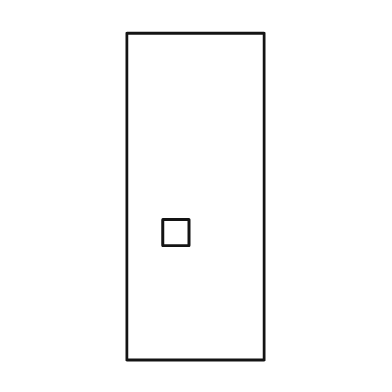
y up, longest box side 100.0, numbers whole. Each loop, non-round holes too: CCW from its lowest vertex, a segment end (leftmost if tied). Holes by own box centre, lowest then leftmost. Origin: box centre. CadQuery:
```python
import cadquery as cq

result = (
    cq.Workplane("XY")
    .moveTo(-21.0, -50.0)
    .lineTo(21.0, -50.0)
    .lineTo(21.0, 50.0)
    .lineTo(-21.0, 50.0)
    .close()
    .moveTo(-10.0, -15.0)
    .lineTo(-2.0, -15.0)
    .lineTo(-2.0, -7.0)
    .lineTo(-10.0, -7.0)
    .close()
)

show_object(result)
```